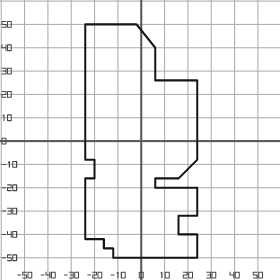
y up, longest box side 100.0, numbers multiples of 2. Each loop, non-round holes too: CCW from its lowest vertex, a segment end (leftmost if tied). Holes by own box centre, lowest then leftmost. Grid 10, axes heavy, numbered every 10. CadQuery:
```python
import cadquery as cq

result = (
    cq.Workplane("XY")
    .moveTo(-12.0, -50.0)
    .lineTo(24.0, -50.0)
    .lineTo(24.0, -40.0)
    .lineTo(16.0, -40.0)
    .lineTo(16.0, -32.0)
    .lineTo(24.0, -32.0)
    .lineTo(24.0, -20.0)
    .lineTo(6.0, -20.0)
    .lineTo(6.0, -16.0)
    .lineTo(16.0, -16.0)
    .lineTo(24.0, -8.0)
    .lineTo(24.0, 26.0)
    .lineTo(6.0, 26.0)
    .lineTo(6.0, 40.0)
    .lineTo(-2.0, 50.0)
    .lineTo(-24.0, 50.0)
    .lineTo(-24.0, -8.0)
    .lineTo(-20.0, -8.0)
    .lineTo(-20.0, -16.0)
    .lineTo(-24.0, -16.0)
    .lineTo(-24.0, -42.0)
    .lineTo(-16.0, -42.0)
    .lineTo(-16.0, -46.0)
    .lineTo(-12.0, -46.0)
    .close()
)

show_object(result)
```